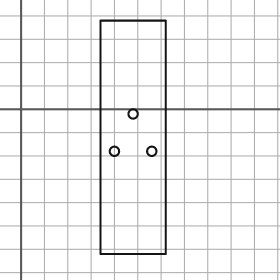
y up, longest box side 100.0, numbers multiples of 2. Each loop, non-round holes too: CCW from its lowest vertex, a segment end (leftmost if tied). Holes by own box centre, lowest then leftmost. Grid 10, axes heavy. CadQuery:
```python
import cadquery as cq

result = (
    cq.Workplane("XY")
    .moveTo(34.0, -62.0)
    .lineTo(62.0, -62.0)
    .lineTo(62.0, 38.0)
    .lineTo(34.0, 38.0)
    .close()
    .moveTo(40.0, -18.0)
    .circle(2.0)
    .moveTo(56.0, -18.0)
    .circle(2.0)
    .moveTo(48.0, -2.0)
    .circle(2.0)
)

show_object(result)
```